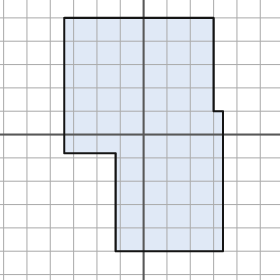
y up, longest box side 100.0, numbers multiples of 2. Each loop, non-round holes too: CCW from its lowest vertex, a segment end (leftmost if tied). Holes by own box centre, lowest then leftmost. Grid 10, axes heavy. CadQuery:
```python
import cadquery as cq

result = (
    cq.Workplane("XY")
    .moveTo(-12.0, -50.0)
    .lineTo(34.0, -50.0)
    .lineTo(34.0, 10.0)
    .lineTo(30.0, 10.0)
    .lineTo(30.0, 50.0)
    .lineTo(-34.0, 50.0)
    .lineTo(-34.0, -8.0)
    .lineTo(-12.0, -8.0)
    .close()
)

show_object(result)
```